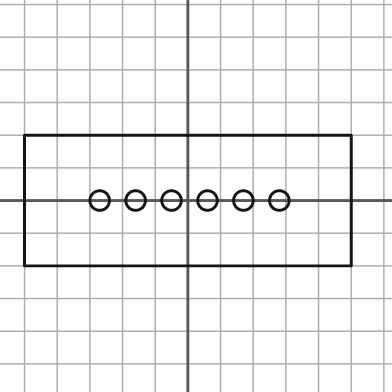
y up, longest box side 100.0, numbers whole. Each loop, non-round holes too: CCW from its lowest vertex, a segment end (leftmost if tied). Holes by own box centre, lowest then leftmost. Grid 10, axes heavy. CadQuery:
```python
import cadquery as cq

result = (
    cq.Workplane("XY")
    .moveTo(-50.0, -20.0)
    .lineTo(50.0, -20.0)
    .lineTo(50.0, 20.0)
    .lineTo(-50.0, 20.0)
    .close()
    .moveTo(-27.0, 0.0)
    .circle(3.0)
    .moveTo(-16.0, 0.0)
    .circle(3.0)
    .moveTo(-5.0, 0.0)
    .circle(3.0)
    .moveTo(6.0, 0.0)
    .circle(3.0)
    .moveTo(17.0, 0.0)
    .circle(3.0)
    .moveTo(28.0, 0.0)
    .circle(3.0)
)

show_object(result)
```